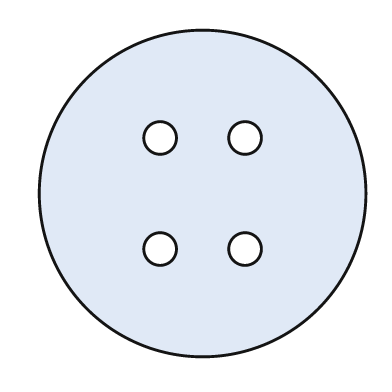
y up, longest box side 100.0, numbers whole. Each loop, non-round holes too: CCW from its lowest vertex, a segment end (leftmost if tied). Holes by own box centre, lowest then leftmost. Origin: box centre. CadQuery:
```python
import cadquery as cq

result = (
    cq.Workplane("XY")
    .moveTo(0.0, 0.0)
    .circle(50.0)
    .moveTo(-13.0, -17.0)
    .circle(5.0)
    .moveTo(13.0, -17.0)
    .circle(5.0)
    .moveTo(-13.0, 17.0)
    .circle(5.0)
    .moveTo(13.0, 17.0)
    .circle(5.0)
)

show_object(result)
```